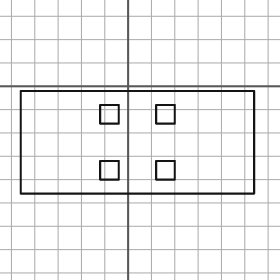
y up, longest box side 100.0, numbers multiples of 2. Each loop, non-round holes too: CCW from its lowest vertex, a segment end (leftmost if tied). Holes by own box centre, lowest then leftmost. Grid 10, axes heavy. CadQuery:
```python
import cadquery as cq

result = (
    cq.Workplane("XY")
    .moveTo(-46.0, -46.0)
    .lineTo(54.0, -46.0)
    .lineTo(54.0, -2.0)
    .lineTo(-46.0, -2.0)
    .close()
    .moveTo(-12.0, -40.0)
    .lineTo(-4.0, -40.0)
    .lineTo(-4.0, -32.0)
    .lineTo(-12.0, -32.0)
    .close()
    .moveTo(12.0, -40.0)
    .lineTo(20.0, -40.0)
    .lineTo(20.0, -32.0)
    .lineTo(12.0, -32.0)
    .close()
    .moveTo(-12.0, -16.0)
    .lineTo(-4.0, -16.0)
    .lineTo(-4.0, -8.0)
    .lineTo(-12.0, -8.0)
    .close()
    .moveTo(12.0, -16.0)
    .lineTo(20.0, -16.0)
    .lineTo(20.0, -8.0)
    .lineTo(12.0, -8.0)
    .close()
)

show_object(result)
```